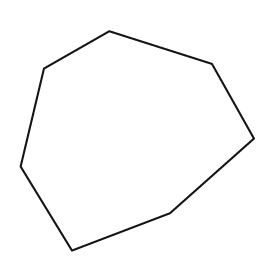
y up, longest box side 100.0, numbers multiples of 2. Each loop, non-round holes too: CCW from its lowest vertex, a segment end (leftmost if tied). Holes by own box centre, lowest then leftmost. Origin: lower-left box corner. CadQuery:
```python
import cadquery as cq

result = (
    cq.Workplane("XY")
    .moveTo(22.0, 0.0)
    .lineTo(64.0, 16.0)
    .lineTo(100.0, 48.0)
    .lineTo(82.0, 80.0)
    .lineTo(38.0, 94.0)
    .lineTo(10.0, 78.0)
    .lineTo(0.0, 36.0)
    .close()
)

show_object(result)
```